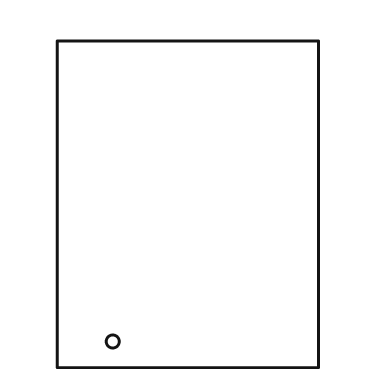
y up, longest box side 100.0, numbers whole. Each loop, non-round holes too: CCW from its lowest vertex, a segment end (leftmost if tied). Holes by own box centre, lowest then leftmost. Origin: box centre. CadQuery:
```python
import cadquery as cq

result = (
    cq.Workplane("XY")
    .moveTo(-40.0, -50.0)
    .lineTo(40.0, -50.0)
    .lineTo(40.0, 50.0)
    .lineTo(-40.0, 50.0)
    .close()
    .moveTo(-23.0, -42.0)
    .circle(2.0)
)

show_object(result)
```